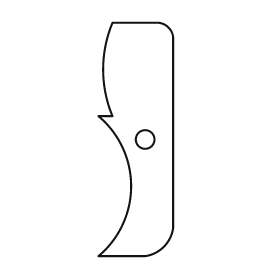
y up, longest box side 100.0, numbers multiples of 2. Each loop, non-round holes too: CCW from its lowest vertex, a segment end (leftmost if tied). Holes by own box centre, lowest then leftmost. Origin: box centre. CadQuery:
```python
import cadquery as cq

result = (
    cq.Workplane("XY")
    .moveTo(-16.0, -50.0)
    .lineTo(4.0, -50.0)
    .threePointArc((12.0, -46.0), (16.0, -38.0))
    .lineTo(16.0, 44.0)
    .threePointArc((14.0, 48.0), (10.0, 50.0))
    .lineTo(-10.0, 50.0)
    .threePointArc((-14.0, 30.0), (-10.0, 10.0))
    .lineTo(-16.0, 10.0)
    .threePointArc((-2.0, -20.0), (-16.0, -50.0))
    .close()
    .moveTo(4.0, 0.0)
    .circle(4.0)
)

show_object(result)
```